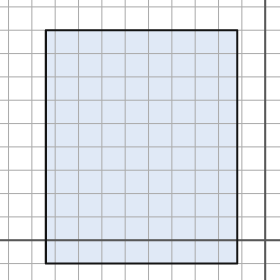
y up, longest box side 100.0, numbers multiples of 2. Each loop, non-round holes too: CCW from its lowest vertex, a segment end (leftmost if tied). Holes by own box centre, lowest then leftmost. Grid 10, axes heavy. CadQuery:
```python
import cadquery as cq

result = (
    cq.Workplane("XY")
    .moveTo(-94.0, -10.0)
    .lineTo(-12.0, -10.0)
    .lineTo(-12.0, 90.0)
    .lineTo(-94.0, 90.0)
    .close()
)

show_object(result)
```